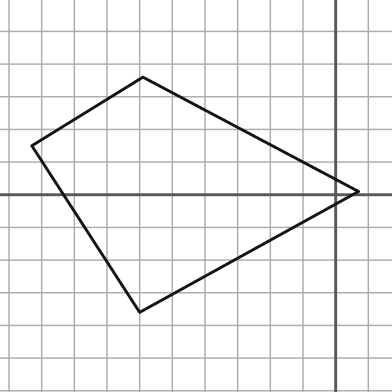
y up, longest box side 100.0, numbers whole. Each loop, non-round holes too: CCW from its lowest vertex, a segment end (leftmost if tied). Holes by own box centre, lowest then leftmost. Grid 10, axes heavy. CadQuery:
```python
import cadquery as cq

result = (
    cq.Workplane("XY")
    .moveTo(-60.0, -36.0)
    .lineTo(7.0, 1.0)
    .lineTo(-59.0, 36.0)
    .lineTo(-93.0, 15.0)
    .close()
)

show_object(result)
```